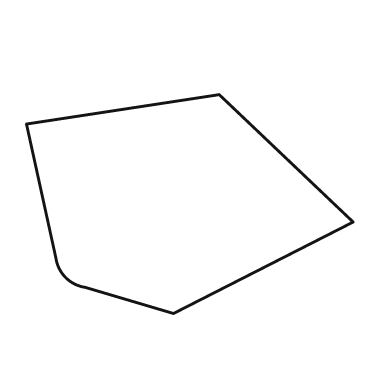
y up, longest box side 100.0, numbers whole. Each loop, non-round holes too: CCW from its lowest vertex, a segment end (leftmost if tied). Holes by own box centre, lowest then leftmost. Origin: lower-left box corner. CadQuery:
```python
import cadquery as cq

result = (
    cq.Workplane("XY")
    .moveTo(45.0, 0.0)
    .lineTo(100.0, 28.0)
    .lineTo(59.0, 67.0)
    .lineTo(0.0, 58.0)
    .lineTo(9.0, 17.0)
    .threePointArc((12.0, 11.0), (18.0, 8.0))
    .close()
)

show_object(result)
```